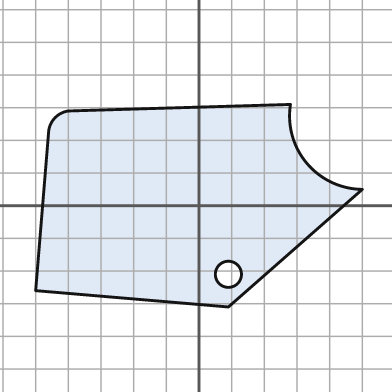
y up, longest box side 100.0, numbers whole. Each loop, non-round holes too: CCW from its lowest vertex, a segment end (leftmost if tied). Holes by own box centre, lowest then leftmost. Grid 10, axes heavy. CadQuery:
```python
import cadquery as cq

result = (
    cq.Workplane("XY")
    .moveTo(9.0, -31.0)
    .lineTo(50.0, 5.0)
    .threePointArc((33.0, 13.0), (28.0, 31.0))
    .lineTo(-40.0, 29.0)
    .threePointArc((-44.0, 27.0), (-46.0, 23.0))
    .lineTo(-50.0, -26.0)
    .close()
    .moveTo(9.0, -21.0)
    .circle(4.0)
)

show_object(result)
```